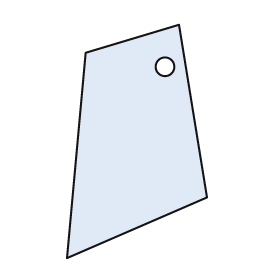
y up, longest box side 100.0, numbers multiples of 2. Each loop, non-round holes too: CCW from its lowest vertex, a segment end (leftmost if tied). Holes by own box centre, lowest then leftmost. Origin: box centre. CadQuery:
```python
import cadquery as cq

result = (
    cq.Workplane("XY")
    .moveTo(-30.0, -50.0)
    .lineTo(30.0, -24.0)
    .lineTo(18.0, 50.0)
    .lineTo(-22.0, 38.0)
    .close()
    .moveTo(12.0, 32.0)
    .circle(4.0)
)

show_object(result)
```